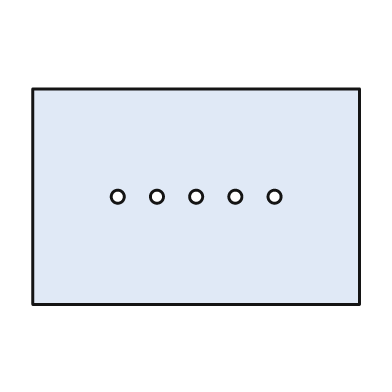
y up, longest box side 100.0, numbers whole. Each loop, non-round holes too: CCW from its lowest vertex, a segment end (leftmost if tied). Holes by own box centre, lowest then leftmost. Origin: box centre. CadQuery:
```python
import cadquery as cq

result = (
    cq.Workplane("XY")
    .moveTo(-50.0, -33.0)
    .lineTo(50.0, -33.0)
    .lineTo(50.0, 33.0)
    .lineTo(-50.0, 33.0)
    .close()
    .moveTo(-24.0, 0.0)
    .circle(2.0)
    .moveTo(-12.0, 0.0)
    .circle(2.0)
    .moveTo(0.0, 0.0)
    .circle(2.0)
    .moveTo(12.0, 0.0)
    .circle(2.0)
    .moveTo(24.0, 0.0)
    .circle(2.0)
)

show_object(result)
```